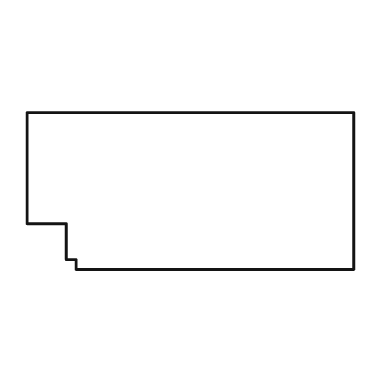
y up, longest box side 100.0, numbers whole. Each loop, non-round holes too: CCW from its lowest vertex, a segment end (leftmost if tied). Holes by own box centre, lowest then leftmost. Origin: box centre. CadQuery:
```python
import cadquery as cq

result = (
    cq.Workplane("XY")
    .moveTo(-35.0, -24.0)
    .lineTo(50.0, -24.0)
    .lineTo(50.0, 24.0)
    .lineTo(-50.0, 24.0)
    .lineTo(-50.0, -10.0)
    .lineTo(-38.0, -10.0)
    .lineTo(-38.0, -21.0)
    .lineTo(-35.0, -21.0)
    .close()
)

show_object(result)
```